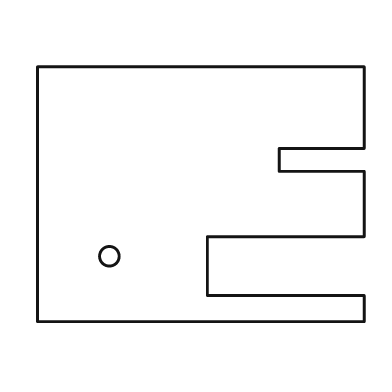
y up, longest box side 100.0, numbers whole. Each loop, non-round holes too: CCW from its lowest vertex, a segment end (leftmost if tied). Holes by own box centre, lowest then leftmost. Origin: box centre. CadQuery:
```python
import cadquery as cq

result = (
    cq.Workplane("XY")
    .moveTo(-50.0, -39.0)
    .lineTo(50.0, -39.0)
    .lineTo(50.0, -31.0)
    .lineTo(2.0, -31.0)
    .lineTo(2.0, -13.0)
    .lineTo(50.0, -13.0)
    .lineTo(50.0, 7.0)
    .lineTo(24.0, 7.0)
    .lineTo(24.0, 14.0)
    .lineTo(50.0, 14.0)
    .lineTo(50.0, 39.0)
    .lineTo(-50.0, 39.0)
    .close()
    .moveTo(-28.0, -19.0)
    .circle(3.0)
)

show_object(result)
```